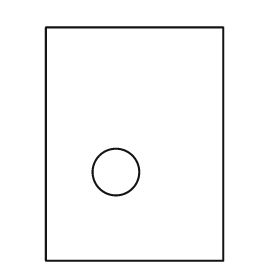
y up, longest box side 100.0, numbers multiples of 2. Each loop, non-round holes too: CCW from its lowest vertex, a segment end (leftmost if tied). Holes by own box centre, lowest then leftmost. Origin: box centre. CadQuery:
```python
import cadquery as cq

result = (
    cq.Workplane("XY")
    .moveTo(-38.0, -50.0)
    .lineTo(38.0, -50.0)
    .lineTo(38.0, 50.0)
    .lineTo(-38.0, 50.0)
    .close()
    .moveTo(-8.0, -12.0)
    .circle(10.0)
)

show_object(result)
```